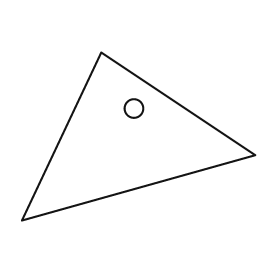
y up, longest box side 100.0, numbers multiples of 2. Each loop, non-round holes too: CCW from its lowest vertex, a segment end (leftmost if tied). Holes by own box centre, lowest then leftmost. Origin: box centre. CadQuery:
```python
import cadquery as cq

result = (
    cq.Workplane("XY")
    .moveTo(-50.0, -36.0)
    .lineTo(50.0, -8.0)
    .lineTo(-16.0, 36.0)
    .close()
    .moveTo(-2.0, 12.0)
    .circle(4.0)
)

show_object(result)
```